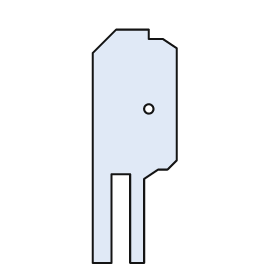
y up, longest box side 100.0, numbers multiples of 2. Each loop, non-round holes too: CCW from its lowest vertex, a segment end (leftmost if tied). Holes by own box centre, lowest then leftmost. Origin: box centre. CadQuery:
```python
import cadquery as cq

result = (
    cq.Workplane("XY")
    .moveTo(-18.0, -50.0)
    .lineTo(-10.0, -50.0)
    .lineTo(-10.0, -12.0)
    .lineTo(-2.0, -12.0)
    .lineTo(-2.0, -50.0)
    .lineTo(4.0, -50.0)
    .lineTo(4.0, -14.0)
    .lineTo(10.0, -10.0)
    .lineTo(14.0, -10.0)
    .lineTo(18.0, -6.0)
    .lineTo(18.0, 42.0)
    .lineTo(12.0, 46.0)
    .lineTo(6.0, 46.0)
    .lineTo(6.0, 50.0)
    .lineTo(-8.0, 50.0)
    .lineTo(-18.0, 40.0)
    .close()
    .moveTo(6.0, 16.0)
    .circle(2.0)
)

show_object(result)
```